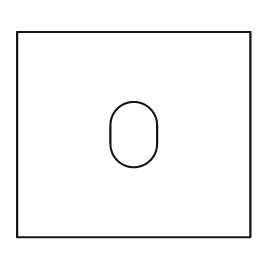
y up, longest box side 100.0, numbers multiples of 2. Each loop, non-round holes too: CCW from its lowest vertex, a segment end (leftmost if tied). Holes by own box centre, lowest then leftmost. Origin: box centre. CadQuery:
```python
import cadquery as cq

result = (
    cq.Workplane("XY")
    .moveTo(-50.0, -44.0)
    .lineTo(50.0, -44.0)
    .lineTo(50.0, 44.0)
    .lineTo(-50.0, 44.0)
    .close()
    .moveTo(-10.0, -4.0)
    .threePointArc((0.0, -14.0), (10.0, -4.0))
    .lineTo(10.0, 4.0)
    .threePointArc((0.0, 14.0), (-10.0, 4.0))
    .close()
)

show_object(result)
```